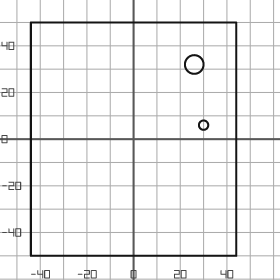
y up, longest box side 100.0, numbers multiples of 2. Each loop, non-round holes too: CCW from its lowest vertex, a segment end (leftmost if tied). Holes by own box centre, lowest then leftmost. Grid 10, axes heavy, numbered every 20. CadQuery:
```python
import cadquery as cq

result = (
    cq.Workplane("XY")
    .moveTo(-44.0, -50.0)
    .lineTo(44.0, -50.0)
    .lineTo(44.0, 50.0)
    .lineTo(-44.0, 50.0)
    .close()
    .moveTo(30.0, 6.0)
    .circle(2.0)
    .moveTo(26.0, 32.0)
    .circle(4.0)
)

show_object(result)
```